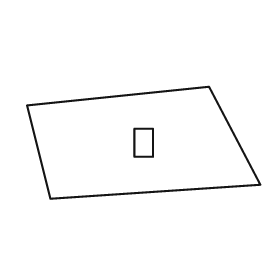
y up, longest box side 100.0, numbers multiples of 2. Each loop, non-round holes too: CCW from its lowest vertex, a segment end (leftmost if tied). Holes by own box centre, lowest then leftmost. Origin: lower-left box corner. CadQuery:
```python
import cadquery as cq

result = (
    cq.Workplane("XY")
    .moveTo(10.0, 0.0)
    .lineTo(100.0, 6.0)
    .lineTo(78.0, 48.0)
    .lineTo(0.0, 40.0)
    .close()
    .moveTo(46.0, 18.0)
    .lineTo(54.0, 18.0)
    .lineTo(54.0, 30.0)
    .lineTo(46.0, 30.0)
    .close()
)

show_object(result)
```